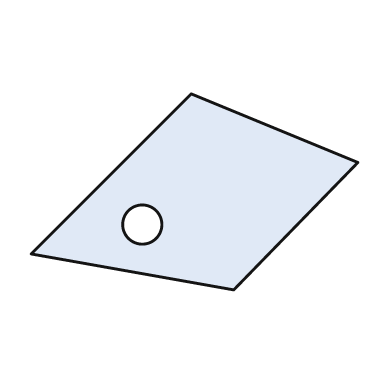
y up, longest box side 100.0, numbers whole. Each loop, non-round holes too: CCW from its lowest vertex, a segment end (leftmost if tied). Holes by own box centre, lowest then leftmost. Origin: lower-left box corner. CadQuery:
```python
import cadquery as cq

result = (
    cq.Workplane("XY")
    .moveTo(62.0, 0.0)
    .lineTo(100.0, 39.0)
    .lineTo(49.0, 60.0)
    .lineTo(0.0, 11.0)
    .close()
    .moveTo(34.0, 20.0)
    .circle(6.0)
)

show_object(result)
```